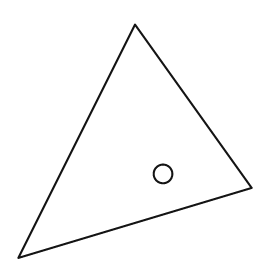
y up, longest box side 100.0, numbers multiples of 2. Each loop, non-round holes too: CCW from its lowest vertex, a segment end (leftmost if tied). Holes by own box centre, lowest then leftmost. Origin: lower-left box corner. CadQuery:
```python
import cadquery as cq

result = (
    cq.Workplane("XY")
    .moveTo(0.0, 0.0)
    .lineTo(100.0, 30.0)
    .lineTo(50.0, 100.0)
    .close()
    .moveTo(62.0, 36.0)
    .circle(4.0)
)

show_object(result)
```